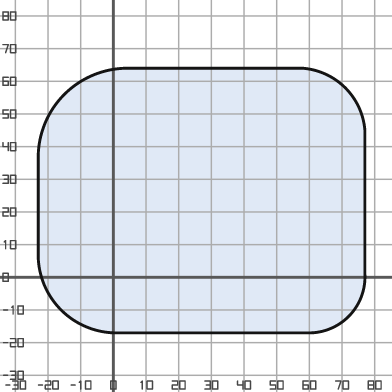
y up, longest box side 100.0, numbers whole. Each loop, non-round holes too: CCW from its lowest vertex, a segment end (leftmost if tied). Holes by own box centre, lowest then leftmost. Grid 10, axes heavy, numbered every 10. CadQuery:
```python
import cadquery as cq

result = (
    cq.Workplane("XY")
    .moveTo(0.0, -17.0)
    .lineTo(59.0, -17.0)
    .threePointArc((72.0, -12.0), (77.0, 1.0))
    .lineTo(77.0, 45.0)
    .threePointArc((71.0, 58.0), (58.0, 64.0))
    .lineTo(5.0, 64.0)
    .threePointArc((-15.0, 56.0), (-23.0, 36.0))
    .lineTo(-23.0, 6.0)
    .threePointArc((-16.0, -10.0), (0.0, -17.0))
    .close()
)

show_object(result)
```